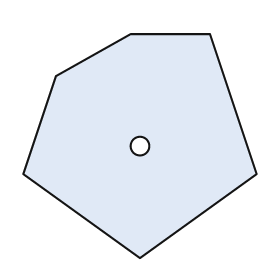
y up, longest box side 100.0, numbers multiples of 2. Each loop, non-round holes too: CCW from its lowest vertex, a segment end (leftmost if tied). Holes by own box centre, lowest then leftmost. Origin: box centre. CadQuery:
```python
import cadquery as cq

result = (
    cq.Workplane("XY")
    .moveTo(0.0, -48.0)
    .lineTo(50.0, -12.0)
    .lineTo(30.0, 48.0)
    .lineTo(-4.0, 48.0)
    .lineTo(-36.0, 30.0)
    .lineTo(-50.0, -12.0)
    .close()
    .moveTo(0.0, 0.0)
    .circle(4.0)
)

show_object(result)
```